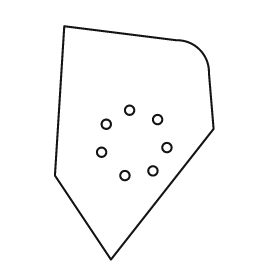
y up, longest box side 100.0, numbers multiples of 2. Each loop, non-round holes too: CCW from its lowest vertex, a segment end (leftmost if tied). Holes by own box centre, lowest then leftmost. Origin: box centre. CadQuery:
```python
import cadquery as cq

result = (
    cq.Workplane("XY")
    .moveTo(-10.0, -50.0)
    .lineTo(34.0, 6.0)
    .lineTo(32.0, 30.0)
    .threePointArc((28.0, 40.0), (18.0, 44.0))
    .lineTo(-30.0, 50.0)
    .lineTo(-34.0, -14.0)
    .close()
    .moveTo(-4.0, -14.0)
    .circle(2.0)
    .moveTo(8.0, -12.0)
    .circle(2.0)
    .moveTo(-14.0, -4.0)
    .circle(2.0)
    .moveTo(14.0, -2.0)
    .circle(2.0)
    .moveTo(-12.0, 8.0)
    .circle(2.0)
    .moveTo(10.0, 10.0)
    .circle(2.0)
    .moveTo(-2.0, 14.0)
    .circle(2.0)
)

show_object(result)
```